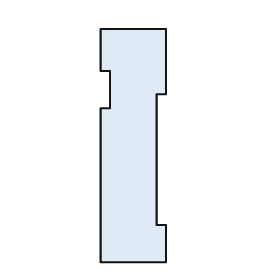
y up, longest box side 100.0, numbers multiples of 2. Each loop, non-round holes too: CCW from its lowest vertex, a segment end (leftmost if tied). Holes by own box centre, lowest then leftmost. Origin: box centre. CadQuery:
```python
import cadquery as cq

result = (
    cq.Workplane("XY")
    .moveTo(-14.0, -50.0)
    .lineTo(14.0, -50.0)
    .lineTo(14.0, -34.0)
    .lineTo(10.0, -34.0)
    .lineTo(10.0, 22.0)
    .lineTo(14.0, 22.0)
    .lineTo(14.0, 50.0)
    .lineTo(-14.0, 50.0)
    .lineTo(-14.0, 32.0)
    .lineTo(-10.0, 32.0)
    .lineTo(-10.0, 16.0)
    .lineTo(-14.0, 16.0)
    .close()
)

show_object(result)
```